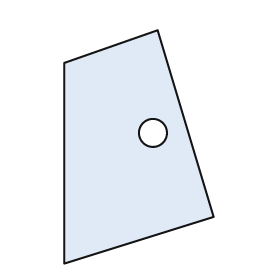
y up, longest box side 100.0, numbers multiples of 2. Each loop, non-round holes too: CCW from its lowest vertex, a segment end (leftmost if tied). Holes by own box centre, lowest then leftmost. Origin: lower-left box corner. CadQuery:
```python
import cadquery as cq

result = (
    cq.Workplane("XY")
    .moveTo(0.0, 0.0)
    .lineTo(64.0, 20.0)
    .lineTo(40.0, 100.0)
    .lineTo(0.0, 86.0)
    .close()
    .moveTo(38.0, 56.0)
    .circle(6.0)
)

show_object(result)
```